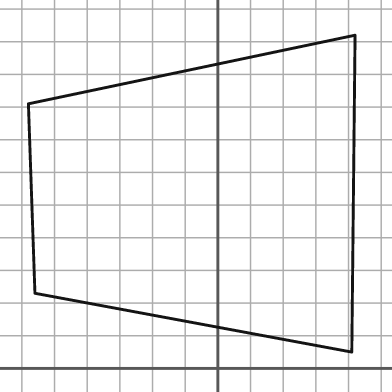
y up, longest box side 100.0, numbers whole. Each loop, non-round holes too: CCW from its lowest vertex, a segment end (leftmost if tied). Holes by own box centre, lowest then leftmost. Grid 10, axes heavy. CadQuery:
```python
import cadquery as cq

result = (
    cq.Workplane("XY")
    .moveTo(41.0, 5.0)
    .lineTo(42.0, 102.0)
    .lineTo(-58.0, 81.0)
    .lineTo(-56.0, 23.0)
    .close()
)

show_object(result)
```